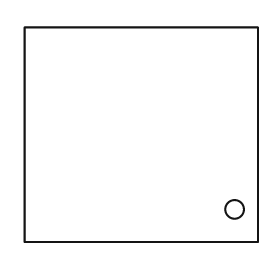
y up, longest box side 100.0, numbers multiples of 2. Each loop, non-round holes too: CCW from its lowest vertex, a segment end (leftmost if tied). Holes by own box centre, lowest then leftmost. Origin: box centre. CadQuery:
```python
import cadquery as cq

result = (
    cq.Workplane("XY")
    .moveTo(-50.0, -46.0)
    .lineTo(50.0, -46.0)
    .lineTo(50.0, 46.0)
    .lineTo(-50.0, 46.0)
    .close()
    .moveTo(40.0, -32.0)
    .circle(4.0)
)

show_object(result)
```